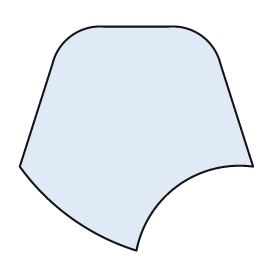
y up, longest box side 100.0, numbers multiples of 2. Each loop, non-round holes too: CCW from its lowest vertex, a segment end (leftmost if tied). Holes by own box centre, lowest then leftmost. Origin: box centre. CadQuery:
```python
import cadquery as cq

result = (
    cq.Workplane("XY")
    .moveTo(0.0, -48.0)
    .threePointArc((18.0, -20.0), (50.0, -12.0))
    .lineTo(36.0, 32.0)
    .threePointArc((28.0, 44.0), (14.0, 48.0))
    .lineTo(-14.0, 48.0)
    .threePointArc((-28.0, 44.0), (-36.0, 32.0))
    .lineTo(-50.0, -12.0)
    .threePointArc((-28.0, -34.0), (0.0, -48.0))
    .close()
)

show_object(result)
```